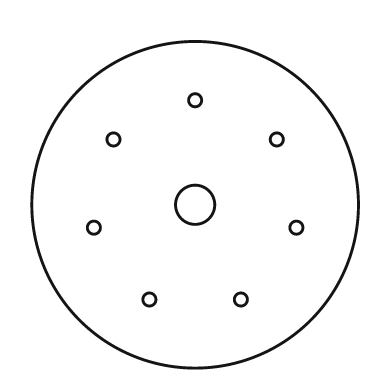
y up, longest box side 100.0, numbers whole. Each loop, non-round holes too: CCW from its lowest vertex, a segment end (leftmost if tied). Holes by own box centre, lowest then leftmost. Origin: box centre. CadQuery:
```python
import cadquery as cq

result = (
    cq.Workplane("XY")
    .moveTo(0.0, 0.0)
    .circle(50.0)
    .moveTo(-14.0, -29.0)
    .circle(2.0)
    .moveTo(14.0, -29.0)
    .circle(2.0)
    .moveTo(-31.0, -7.0)
    .circle(2.0)
    .moveTo(31.0, -7.0)
    .circle(2.0)
    .moveTo(0.0, 0.0)
    .circle(6.0)
    .moveTo(-25.0, 20.0)
    .circle(2.0)
    .moveTo(25.0, 20.0)
    .circle(2.0)
    .moveTo(0.0, 32.0)
    .circle(2.0)
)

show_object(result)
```